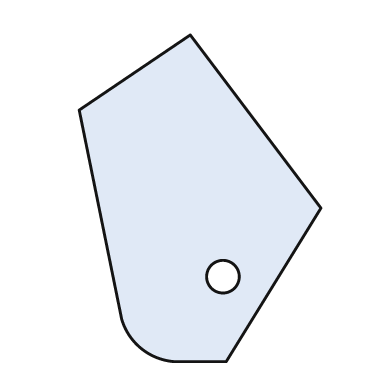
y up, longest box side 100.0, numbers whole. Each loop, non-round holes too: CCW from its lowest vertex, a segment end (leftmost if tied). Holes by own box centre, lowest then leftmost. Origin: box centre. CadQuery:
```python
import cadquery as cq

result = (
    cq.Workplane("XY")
    .moveTo(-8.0, -50.0)
    .lineTo(8.0, -50.0)
    .lineTo(37.0, -3.0)
    .lineTo(-3.0, 50.0)
    .lineTo(-37.0, 27.0)
    .lineTo(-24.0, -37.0)
    .threePointArc((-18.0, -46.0), (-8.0, -50.0))
    .close()
    .moveTo(7.0, -24.0)
    .circle(5.0)
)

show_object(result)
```